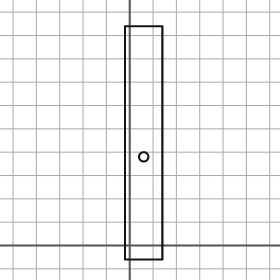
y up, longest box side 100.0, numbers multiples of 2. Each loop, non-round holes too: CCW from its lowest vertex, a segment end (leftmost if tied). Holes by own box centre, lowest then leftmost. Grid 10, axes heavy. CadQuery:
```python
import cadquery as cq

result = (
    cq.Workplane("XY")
    .moveTo(-2.0, -6.0)
    .lineTo(14.0, -6.0)
    .lineTo(14.0, 94.0)
    .lineTo(-2.0, 94.0)
    .close()
    .moveTo(6.0, 38.0)
    .circle(2.0)
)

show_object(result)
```